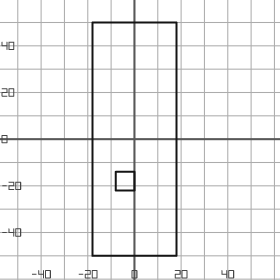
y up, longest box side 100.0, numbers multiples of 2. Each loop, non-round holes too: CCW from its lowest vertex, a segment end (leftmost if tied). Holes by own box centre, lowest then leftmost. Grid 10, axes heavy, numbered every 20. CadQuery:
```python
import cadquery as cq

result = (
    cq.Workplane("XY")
    .moveTo(-18.0, -50.0)
    .lineTo(18.0, -50.0)
    .lineTo(18.0, 50.0)
    .lineTo(-18.0, 50.0)
    .close()
    .moveTo(-8.0, -22.0)
    .lineTo(0.0, -22.0)
    .lineTo(0.0, -14.0)
    .lineTo(-8.0, -14.0)
    .close()
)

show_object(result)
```